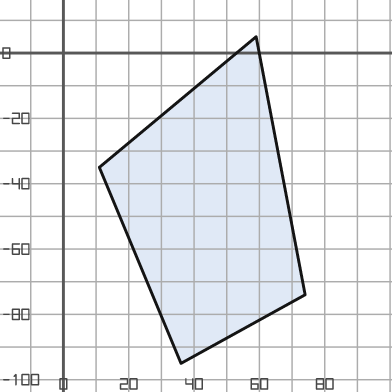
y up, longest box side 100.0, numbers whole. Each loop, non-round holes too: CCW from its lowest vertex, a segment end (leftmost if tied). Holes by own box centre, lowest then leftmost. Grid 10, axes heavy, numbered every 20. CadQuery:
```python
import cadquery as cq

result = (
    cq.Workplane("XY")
    .moveTo(36.0, -95.0)
    .lineTo(74.0, -74.0)
    .lineTo(59.0, 5.0)
    .lineTo(11.0, -35.0)
    .close()
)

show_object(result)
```